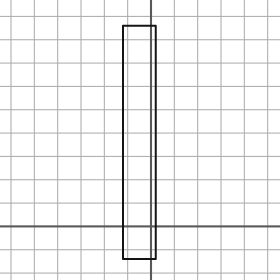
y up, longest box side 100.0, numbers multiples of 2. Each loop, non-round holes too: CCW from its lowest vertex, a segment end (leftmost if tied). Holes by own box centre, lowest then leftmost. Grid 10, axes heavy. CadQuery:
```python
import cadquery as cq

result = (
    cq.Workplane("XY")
    .moveTo(-12.0, -14.0)
    .lineTo(2.0, -14.0)
    .lineTo(2.0, 86.0)
    .lineTo(-12.0, 86.0)
    .close()
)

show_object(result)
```